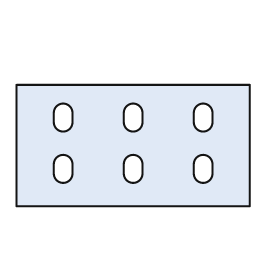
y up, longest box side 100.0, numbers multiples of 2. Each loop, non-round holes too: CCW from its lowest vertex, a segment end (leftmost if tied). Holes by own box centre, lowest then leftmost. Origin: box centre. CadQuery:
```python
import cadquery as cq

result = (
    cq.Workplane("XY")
    .moveTo(-50.0, -26.0)
    .lineTo(50.0, -26.0)
    .lineTo(50.0, 26.0)
    .lineTo(-50.0, 26.0)
    .close()
    .moveTo(-34.0, -12.0)
    .threePointArc((-30.0, -16.0), (-26.0, -12.0))
    .lineTo(-26.0, -8.0)
    .threePointArc((-30.0, -4.0), (-34.0, -8.0))
    .close()
    .moveTo(-4.0, -12.0)
    .threePointArc((0.0, -16.0), (4.0, -12.0))
    .lineTo(4.0, -8.0)
    .threePointArc((0.0, -4.0), (-4.0, -8.0))
    .close()
    .moveTo(26.0, -12.0)
    .threePointArc((30.0, -16.0), (34.0, -12.0))
    .lineTo(34.0, -8.0)
    .threePointArc((30.0, -4.0), (26.0, -8.0))
    .close()
    .moveTo(-34.0, 10.0)
    .threePointArc((-30.0, 6.0), (-26.0, 10.0))
    .lineTo(-26.0, 14.0)
    .threePointArc((-30.0, 18.0), (-34.0, 14.0))
    .close()
    .moveTo(-4.0, 10.0)
    .threePointArc((0.0, 6.0), (4.0, 10.0))
    .lineTo(4.0, 14.0)
    .threePointArc((0.0, 18.0), (-4.0, 14.0))
    .close()
    .moveTo(26.0, 10.0)
    .threePointArc((30.0, 6.0), (34.0, 10.0))
    .lineTo(34.0, 14.0)
    .threePointArc((30.0, 18.0), (26.0, 14.0))
    .close()
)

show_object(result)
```